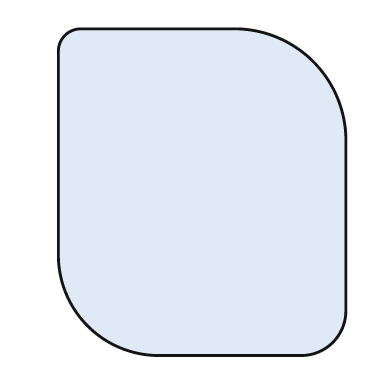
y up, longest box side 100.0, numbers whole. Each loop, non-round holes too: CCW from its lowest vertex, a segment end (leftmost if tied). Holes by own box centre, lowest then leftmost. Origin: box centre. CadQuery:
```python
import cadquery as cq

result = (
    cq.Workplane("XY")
    .moveTo(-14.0, -50.0)
    .lineTo(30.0, -50.0)
    .threePointArc((40.0, -46.0), (44.0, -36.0))
    .lineTo(44.0, 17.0)
    .threePointArc((34.0, 40.0), (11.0, 50.0))
    .lineTo(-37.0, 50.0)
    .threePointArc((-42.0, 48.0), (-44.0, 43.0))
    .lineTo(-44.0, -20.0)
    .threePointArc((-35.0, -41.0), (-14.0, -50.0))
    .close()
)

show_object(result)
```